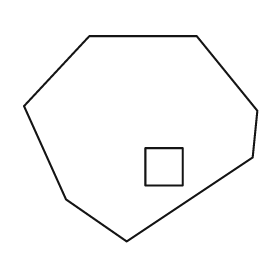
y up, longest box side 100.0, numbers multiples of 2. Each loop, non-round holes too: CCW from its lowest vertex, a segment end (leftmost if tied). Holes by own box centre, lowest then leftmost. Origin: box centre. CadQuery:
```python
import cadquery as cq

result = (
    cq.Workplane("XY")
    .moveTo(-6.0, -44.0)
    .lineTo(48.0, -8.0)
    .lineTo(50.0, 12.0)
    .lineTo(24.0, 44.0)
    .lineTo(-22.0, 44.0)
    .lineTo(-50.0, 14.0)
    .lineTo(-32.0, -26.0)
    .close()
    .moveTo(2.0, -20.0)
    .lineTo(18.0, -20.0)
    .lineTo(18.0, -4.0)
    .lineTo(2.0, -4.0)
    .close()
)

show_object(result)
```